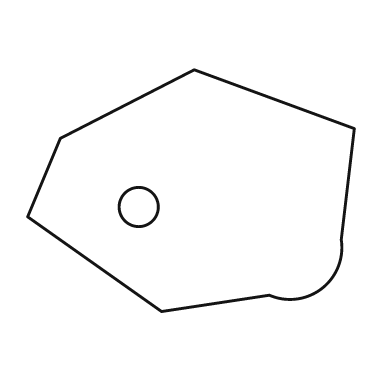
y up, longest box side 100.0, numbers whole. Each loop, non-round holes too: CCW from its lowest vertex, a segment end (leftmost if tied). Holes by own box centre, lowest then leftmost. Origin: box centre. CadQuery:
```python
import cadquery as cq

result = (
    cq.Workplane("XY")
    .moveTo(-9.0, -37.0)
    .lineTo(24.0, -32.0)
    .threePointArc((40.0, -30.0), (46.0, -15.0))
    .lineTo(50.0, 19.0)
    .lineTo(1.0, 37.0)
    .lineTo(-40.0, 16.0)
    .lineTo(-50.0, -8.0)
    .close()
    .moveTo(-16.0, -5.0)
    .circle(6.0)
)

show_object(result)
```